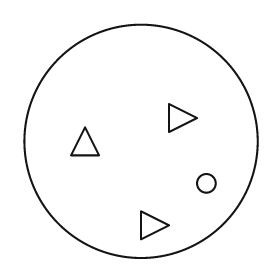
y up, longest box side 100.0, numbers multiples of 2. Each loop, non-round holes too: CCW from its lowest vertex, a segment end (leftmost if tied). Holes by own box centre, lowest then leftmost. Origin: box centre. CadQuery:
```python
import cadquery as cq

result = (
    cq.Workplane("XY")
    .moveTo(0.0, 0.0)
    .circle(50.0)
    .moveTo(0.0, -42.0)
    .lineTo(12.0, -36.0)
    .lineTo(0.0, -30.0)
    .close()
    .moveTo(28.0, -18.0)
    .circle(4.0)
    .moveTo(-30.0, -6.0)
    .lineTo(-18.0, -6.0)
    .lineTo(-24.0, 6.0)
    .close()
    .moveTo(12.0, 4.0)
    .lineTo(24.0, 10.0)
    .lineTo(12.0, 16.0)
    .close()
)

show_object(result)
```